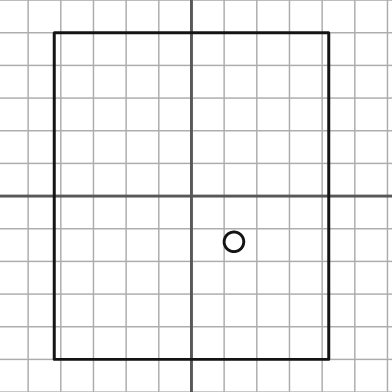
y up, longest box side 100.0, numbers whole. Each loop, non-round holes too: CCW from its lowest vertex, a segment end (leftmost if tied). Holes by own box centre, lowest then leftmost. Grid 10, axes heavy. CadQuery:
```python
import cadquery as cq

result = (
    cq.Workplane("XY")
    .moveTo(-42.0, -50.0)
    .lineTo(42.0, -50.0)
    .lineTo(42.0, 50.0)
    .lineTo(-42.0, 50.0)
    .close()
    .moveTo(13.0, -14.0)
    .circle(3.0)
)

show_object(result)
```